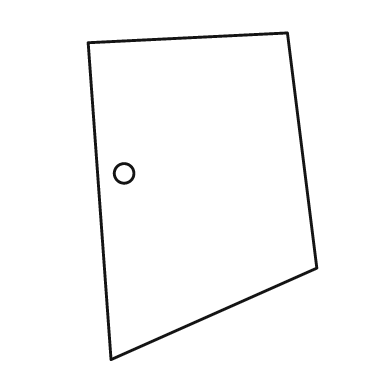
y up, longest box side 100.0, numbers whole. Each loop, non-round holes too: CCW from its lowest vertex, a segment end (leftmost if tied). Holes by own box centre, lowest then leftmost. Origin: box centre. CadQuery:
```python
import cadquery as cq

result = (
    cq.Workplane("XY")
    .moveTo(-28.0, -50.0)
    .lineTo(35.0, -22.0)
    .lineTo(26.0, 50.0)
    .lineTo(-35.0, 47.0)
    .close()
    .moveTo(-24.0, 7.0)
    .circle(3.0)
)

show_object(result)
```